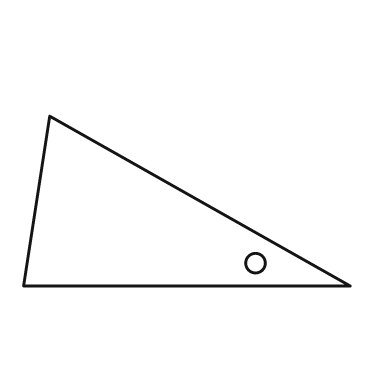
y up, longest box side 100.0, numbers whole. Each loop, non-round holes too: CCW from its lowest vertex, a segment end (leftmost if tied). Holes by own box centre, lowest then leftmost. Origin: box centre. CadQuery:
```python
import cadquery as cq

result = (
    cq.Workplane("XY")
    .moveTo(-50.0, -26.0)
    .lineTo(50.0, -26.0)
    .lineTo(-42.0, 26.0)
    .close()
    .moveTo(21.0, -19.0)
    .circle(3.0)
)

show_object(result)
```